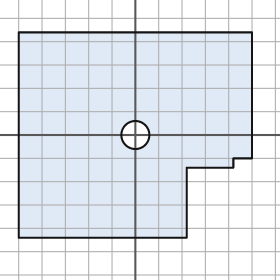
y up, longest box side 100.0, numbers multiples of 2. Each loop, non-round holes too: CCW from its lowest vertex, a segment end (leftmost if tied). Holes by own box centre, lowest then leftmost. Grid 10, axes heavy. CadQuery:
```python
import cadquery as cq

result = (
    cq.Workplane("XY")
    .moveTo(-50.0, -44.0)
    .lineTo(22.0, -44.0)
    .lineTo(22.0, -14.0)
    .lineTo(42.0, -14.0)
    .lineTo(42.0, -10.0)
    .lineTo(50.0, -10.0)
    .lineTo(50.0, 44.0)
    .lineTo(-50.0, 44.0)
    .close()
    .moveTo(0.0, 0.0)
    .circle(6.0)
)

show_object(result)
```